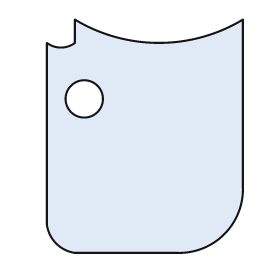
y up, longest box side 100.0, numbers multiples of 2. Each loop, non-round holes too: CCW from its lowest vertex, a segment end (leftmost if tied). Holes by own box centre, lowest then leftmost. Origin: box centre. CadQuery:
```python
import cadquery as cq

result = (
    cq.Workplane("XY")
    .moveTo(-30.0, -50.0)
    .lineTo(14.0, -50.0)
    .threePointArc((34.0, -42.0), (42.0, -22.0))
    .lineTo(42.0, 50.0)
    .threePointArc((6.0, 40.0), (-30.0, 50.0))
    .lineTo(-30.0, 40.0)
    .threePointArc((-36.0, 38.0), (-42.0, 40.0))
    .lineTo(-42.0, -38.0)
    .threePointArc((-38.0, -46.0), (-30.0, -50.0))
    .close()
    .moveTo(-26.0, 16.0)
    .circle(8.0)
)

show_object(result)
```